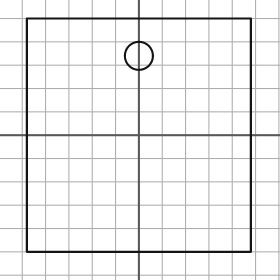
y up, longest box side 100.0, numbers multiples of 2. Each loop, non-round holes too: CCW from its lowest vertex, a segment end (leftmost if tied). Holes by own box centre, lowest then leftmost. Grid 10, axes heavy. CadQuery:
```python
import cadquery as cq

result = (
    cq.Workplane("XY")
    .moveTo(-48.0, -50.0)
    .lineTo(48.0, -50.0)
    .lineTo(48.0, 50.0)
    .lineTo(-48.0, 50.0)
    .close()
    .moveTo(0.0, 34.0)
    .circle(6.0)
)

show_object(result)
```